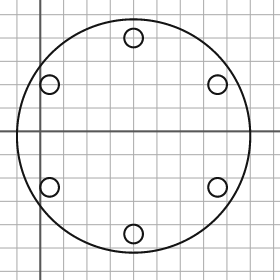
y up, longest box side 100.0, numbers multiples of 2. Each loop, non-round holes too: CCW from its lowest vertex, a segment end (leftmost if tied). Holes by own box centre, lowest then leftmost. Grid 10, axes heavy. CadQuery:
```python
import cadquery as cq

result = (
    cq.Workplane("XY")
    .moveTo(40.0, -2.0)
    .circle(50.0)
    .moveTo(40.0, -44.0)
    .circle(4.0)
    .moveTo(4.0, -24.0)
    .circle(4.0)
    .moveTo(76.0, -24.0)
    .circle(4.0)
    .moveTo(4.0, 20.0)
    .circle(4.0)
    .moveTo(76.0, 20.0)
    .circle(4.0)
    .moveTo(40.0, 40.0)
    .circle(4.0)
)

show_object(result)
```